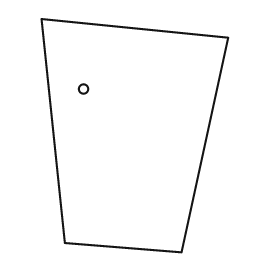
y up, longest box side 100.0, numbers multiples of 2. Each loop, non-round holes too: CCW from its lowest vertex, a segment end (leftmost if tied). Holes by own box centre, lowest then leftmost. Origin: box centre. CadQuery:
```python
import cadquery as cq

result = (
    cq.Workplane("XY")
    .moveTo(20.0, -50.0)
    .lineTo(40.0, 42.0)
    .lineTo(-40.0, 50.0)
    .lineTo(-30.0, -46.0)
    .close()
    .moveTo(-22.0, 20.0)
    .circle(2.0)
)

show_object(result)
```